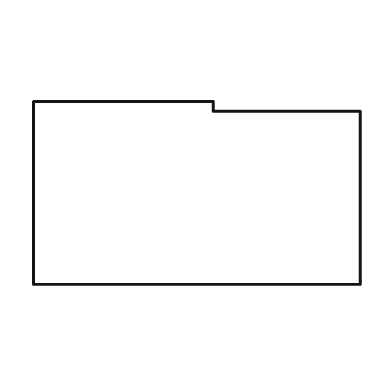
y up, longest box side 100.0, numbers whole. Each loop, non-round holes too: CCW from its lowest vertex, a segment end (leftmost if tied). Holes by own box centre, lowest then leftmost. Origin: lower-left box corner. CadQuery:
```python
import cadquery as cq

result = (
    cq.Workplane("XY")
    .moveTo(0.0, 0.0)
    .lineTo(100.0, 0.0)
    .lineTo(100.0, 53.0)
    .lineTo(55.0, 53.0)
    .lineTo(55.0, 56.0)
    .lineTo(0.0, 56.0)
    .close()
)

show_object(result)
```